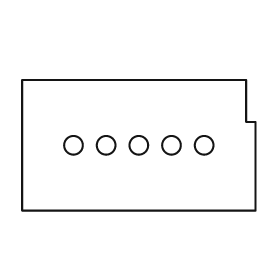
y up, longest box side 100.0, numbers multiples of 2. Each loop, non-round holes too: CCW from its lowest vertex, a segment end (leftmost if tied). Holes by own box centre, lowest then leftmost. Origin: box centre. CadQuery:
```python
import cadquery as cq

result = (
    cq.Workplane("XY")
    .moveTo(-50.0, -28.0)
    .lineTo(50.0, -28.0)
    .lineTo(50.0, 10.0)
    .lineTo(46.0, 10.0)
    .lineTo(46.0, 28.0)
    .lineTo(-50.0, 28.0)
    .close()
    .moveTo(-28.0, 0.0)
    .circle(4.0)
    .moveTo(-14.0, 0.0)
    .circle(4.0)
    .moveTo(0.0, 0.0)
    .circle(4.0)
    .moveTo(14.0, 0.0)
    .circle(4.0)
    .moveTo(28.0, 0.0)
    .circle(4.0)
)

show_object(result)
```